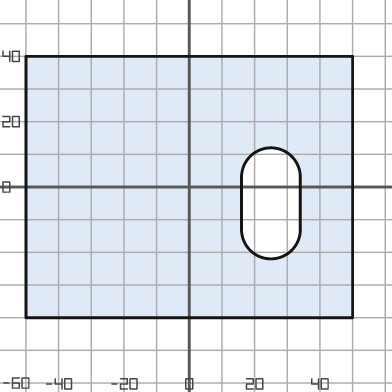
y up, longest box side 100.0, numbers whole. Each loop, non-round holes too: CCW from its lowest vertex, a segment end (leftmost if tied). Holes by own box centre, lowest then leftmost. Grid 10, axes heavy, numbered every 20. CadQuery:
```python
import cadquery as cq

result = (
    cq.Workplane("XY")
    .moveTo(-50.0, -40.0)
    .lineTo(50.0, -40.0)
    .lineTo(50.0, 40.0)
    .lineTo(-50.0, 40.0)
    .close()
    .moveTo(16.0, -13.0)
    .threePointArc((25.0, -22.0), (34.0, -13.0))
    .lineTo(34.0, 3.0)
    .threePointArc((25.0, 12.0), (16.0, 3.0))
    .close()
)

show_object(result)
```